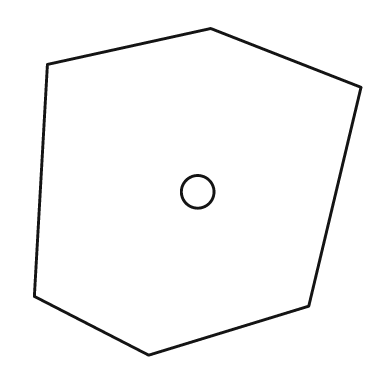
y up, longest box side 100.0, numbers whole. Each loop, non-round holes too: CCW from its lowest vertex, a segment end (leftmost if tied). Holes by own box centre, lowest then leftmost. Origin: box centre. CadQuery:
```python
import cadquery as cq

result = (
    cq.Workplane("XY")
    .moveTo(-15.0, -50.0)
    .lineTo(34.0, -35.0)
    .lineTo(50.0, 32.0)
    .lineTo(4.0, 50.0)
    .lineTo(-46.0, 39.0)
    .lineTo(-50.0, -32.0)
    .close()
    .moveTo(0.0, 0.0)
    .circle(5.0)
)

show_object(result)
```